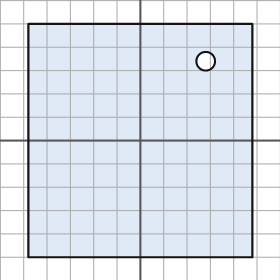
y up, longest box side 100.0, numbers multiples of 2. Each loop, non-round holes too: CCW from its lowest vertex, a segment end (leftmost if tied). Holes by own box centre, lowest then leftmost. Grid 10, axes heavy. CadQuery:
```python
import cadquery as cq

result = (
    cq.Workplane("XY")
    .moveTo(-48.0, -50.0)
    .lineTo(48.0, -50.0)
    .lineTo(48.0, 50.0)
    .lineTo(-48.0, 50.0)
    .close()
    .moveTo(28.0, 34.0)
    .circle(4.0)
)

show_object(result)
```